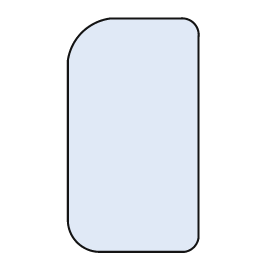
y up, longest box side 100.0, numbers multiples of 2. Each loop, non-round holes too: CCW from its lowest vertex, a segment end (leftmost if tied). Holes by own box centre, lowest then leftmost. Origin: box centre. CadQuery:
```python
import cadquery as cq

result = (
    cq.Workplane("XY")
    .moveTo(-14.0, -50.0)
    .lineTo(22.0, -50.0)
    .threePointArc((26.0, -48.0), (28.0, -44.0))
    .lineTo(28.0, 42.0)
    .threePointArc((26.0, 48.0), (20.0, 50.0))
    .lineTo(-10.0, 50.0)
    .threePointArc((-22.0, 44.0), (-28.0, 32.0))
    .lineTo(-28.0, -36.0)
    .threePointArc((-24.0, -46.0), (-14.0, -50.0))
    .close()
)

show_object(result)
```